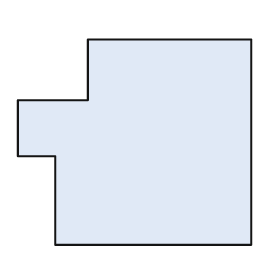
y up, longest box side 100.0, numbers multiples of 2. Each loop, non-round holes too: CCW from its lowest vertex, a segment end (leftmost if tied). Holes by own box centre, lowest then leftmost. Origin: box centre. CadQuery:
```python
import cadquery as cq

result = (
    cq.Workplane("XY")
    .moveTo(-34.0, -44.0)
    .lineTo(50.0, -44.0)
    .lineTo(50.0, 44.0)
    .lineTo(-20.0, 44.0)
    .lineTo(-20.0, 18.0)
    .lineTo(-50.0, 18.0)
    .lineTo(-50.0, -6.0)
    .lineTo(-34.0, -6.0)
    .close()
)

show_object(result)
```